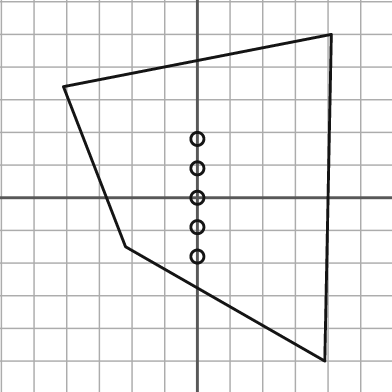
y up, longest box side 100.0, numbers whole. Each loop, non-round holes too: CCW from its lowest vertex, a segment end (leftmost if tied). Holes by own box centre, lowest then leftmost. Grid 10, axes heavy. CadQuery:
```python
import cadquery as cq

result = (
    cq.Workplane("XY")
    .moveTo(39.0, -50.0)
    .lineTo(41.0, 50.0)
    .lineTo(-41.0, 34.0)
    .lineTo(-22.0, -15.0)
    .close()
    .moveTo(0.0, -18.0)
    .circle(2.0)
    .moveTo(0.0, -9.0)
    .circle(2.0)
    .moveTo(0.0, 0.0)
    .circle(2.0)
    .moveTo(0.0, 9.0)
    .circle(2.0)
    .moveTo(0.0, 18.0)
    .circle(2.0)
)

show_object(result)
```